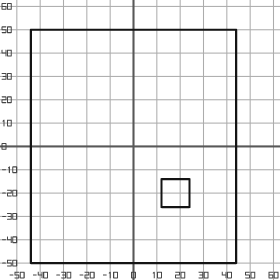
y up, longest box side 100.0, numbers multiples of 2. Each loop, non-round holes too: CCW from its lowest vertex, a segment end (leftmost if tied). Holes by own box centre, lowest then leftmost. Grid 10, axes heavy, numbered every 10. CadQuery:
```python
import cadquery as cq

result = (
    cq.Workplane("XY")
    .moveTo(-44.0, -50.0)
    .lineTo(44.0, -50.0)
    .lineTo(44.0, 50.0)
    .lineTo(-44.0, 50.0)
    .close()
    .moveTo(12.0, -26.0)
    .lineTo(24.0, -26.0)
    .lineTo(24.0, -14.0)
    .lineTo(12.0, -14.0)
    .close()
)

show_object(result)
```